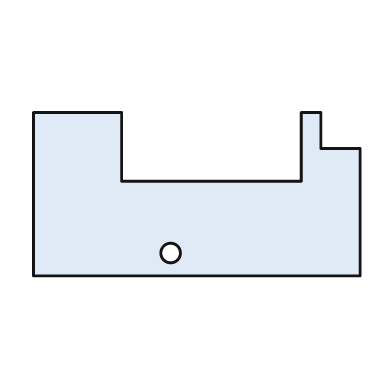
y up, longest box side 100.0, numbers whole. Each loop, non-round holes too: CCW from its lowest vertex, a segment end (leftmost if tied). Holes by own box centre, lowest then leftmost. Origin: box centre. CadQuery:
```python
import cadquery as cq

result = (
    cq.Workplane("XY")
    .moveTo(-50.0, -25.0)
    .lineTo(50.0, -25.0)
    .lineTo(50.0, 14.0)
    .lineTo(38.0, 14.0)
    .lineTo(38.0, 25.0)
    .lineTo(32.0, 25.0)
    .lineTo(32.0, 4.0)
    .lineTo(-23.0, 4.0)
    .lineTo(-23.0, 25.0)
    .lineTo(-50.0, 25.0)
    .close()
    .moveTo(-8.0, -18.0)
    .circle(3.0)
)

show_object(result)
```